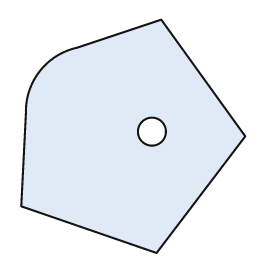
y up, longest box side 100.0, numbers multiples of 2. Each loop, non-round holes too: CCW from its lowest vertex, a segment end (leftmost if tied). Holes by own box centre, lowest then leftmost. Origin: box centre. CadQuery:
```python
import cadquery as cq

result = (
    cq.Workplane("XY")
    .moveTo(10.0, -50.0)
    .lineTo(48.0, 0.0)
    .lineTo(12.0, 50.0)
    .lineTo(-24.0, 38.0)
    .threePointArc((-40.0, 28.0), (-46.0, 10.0))
    .lineTo(-48.0, -30.0)
    .close()
    .moveTo(8.0, 2.0)
    .circle(6.0)
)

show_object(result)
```